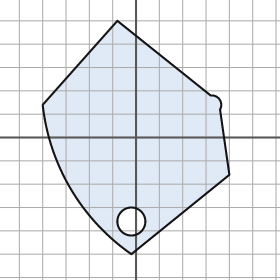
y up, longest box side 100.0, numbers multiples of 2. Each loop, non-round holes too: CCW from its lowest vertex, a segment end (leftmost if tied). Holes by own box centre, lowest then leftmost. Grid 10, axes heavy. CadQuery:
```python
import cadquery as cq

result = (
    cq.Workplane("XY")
    .moveTo(-2.0, -50.0)
    .lineTo(40.0, -16.0)
    .lineTo(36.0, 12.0)
    .threePointArc((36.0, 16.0), (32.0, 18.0))
    .lineTo(-8.0, 50.0)
    .lineTo(-40.0, 14.0)
    .threePointArc((-28.0, -22.0), (-2.0, -50.0))
    .close()
    .moveTo(-2.0, -36.0)
    .circle(6.0)
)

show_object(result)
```